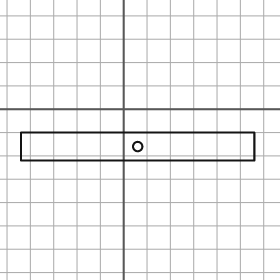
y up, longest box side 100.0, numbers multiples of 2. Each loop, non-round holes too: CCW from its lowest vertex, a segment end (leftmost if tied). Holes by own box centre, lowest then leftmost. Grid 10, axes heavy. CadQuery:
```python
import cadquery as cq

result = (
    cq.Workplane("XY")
    .moveTo(-44.0, -22.0)
    .lineTo(56.0, -22.0)
    .lineTo(56.0, -10.0)
    .lineTo(-44.0, -10.0)
    .close()
    .moveTo(6.0, -16.0)
    .circle(2.0)
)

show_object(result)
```